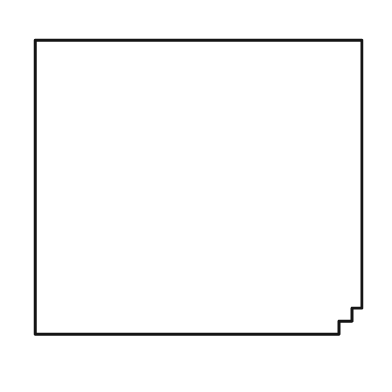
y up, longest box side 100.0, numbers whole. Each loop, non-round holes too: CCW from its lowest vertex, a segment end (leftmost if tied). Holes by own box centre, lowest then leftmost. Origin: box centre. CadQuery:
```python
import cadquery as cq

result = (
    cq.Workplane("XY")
    .moveTo(-50.0, -45.0)
    .lineTo(43.0, -45.0)
    .lineTo(43.0, -41.0)
    .lineTo(47.0, -41.0)
    .lineTo(47.0, -37.0)
    .lineTo(50.0, -37.0)
    .lineTo(50.0, 45.0)
    .lineTo(-50.0, 45.0)
    .close()
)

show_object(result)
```